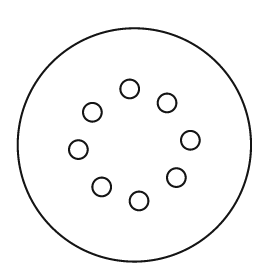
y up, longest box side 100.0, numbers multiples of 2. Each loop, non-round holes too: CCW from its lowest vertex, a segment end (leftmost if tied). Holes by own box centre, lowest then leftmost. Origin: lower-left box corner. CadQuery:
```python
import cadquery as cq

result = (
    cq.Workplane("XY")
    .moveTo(50.0, 50.0)
    .circle(50.0)
    .moveTo(52.0, 26.0)
    .circle(4.0)
    .moveTo(36.0, 32.0)
    .circle(4.0)
    .moveTo(68.0, 36.0)
    .circle(4.0)
    .moveTo(26.0, 48.0)
    .circle(4.0)
    .moveTo(74.0, 52.0)
    .circle(4.0)
    .moveTo(32.0, 64.0)
    .circle(4.0)
    .moveTo(64.0, 68.0)
    .circle(4.0)
    .moveTo(48.0, 74.0)
    .circle(4.0)
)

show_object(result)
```